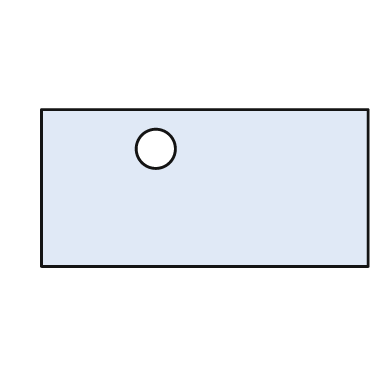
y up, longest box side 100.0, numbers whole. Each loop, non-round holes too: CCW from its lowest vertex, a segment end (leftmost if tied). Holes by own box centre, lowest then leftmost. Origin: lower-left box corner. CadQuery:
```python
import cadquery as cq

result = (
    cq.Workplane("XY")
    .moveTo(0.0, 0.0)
    .lineTo(100.0, 0.0)
    .lineTo(100.0, 48.0)
    .lineTo(0.0, 48.0)
    .close()
    .moveTo(35.0, 36.0)
    .circle(6.0)
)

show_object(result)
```